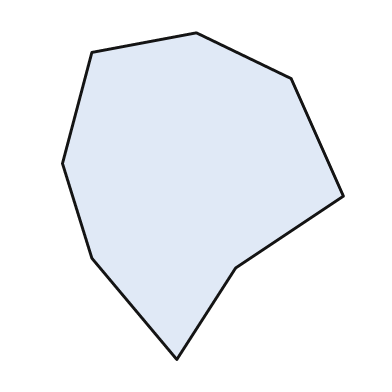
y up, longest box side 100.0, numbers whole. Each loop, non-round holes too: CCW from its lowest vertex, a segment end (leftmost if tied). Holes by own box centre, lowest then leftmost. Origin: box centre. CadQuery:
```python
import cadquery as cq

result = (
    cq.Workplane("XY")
    .moveTo(-8.0, -50.0)
    .lineTo(10.0, -22.0)
    .lineTo(43.0, 0.0)
    .lineTo(27.0, 36.0)
    .lineTo(-2.0, 50.0)
    .lineTo(-34.0, 44.0)
    .lineTo(-43.0, 10.0)
    .lineTo(-34.0, -19.0)
    .close()
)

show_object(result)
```